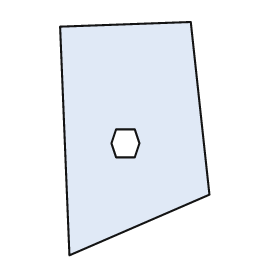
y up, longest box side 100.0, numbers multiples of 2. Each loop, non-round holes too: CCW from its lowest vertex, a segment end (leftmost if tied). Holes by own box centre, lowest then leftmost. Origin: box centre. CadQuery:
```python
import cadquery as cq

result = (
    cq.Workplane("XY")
    .moveTo(-28.0, -50.0)
    .lineTo(32.0, -24.0)
    .lineTo(24.0, 50.0)
    .lineTo(-32.0, 48.0)
    .close()
    .moveTo(-8.0, -8.0)
    .lineTo(0.0, -8.0)
    .lineTo(2.0, -2.0)
    .lineTo(0.0, 4.0)
    .lineTo(-8.0, 4.0)
    .lineTo(-10.0, -2.0)
    .close()
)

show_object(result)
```